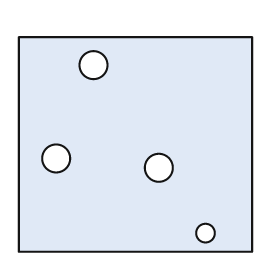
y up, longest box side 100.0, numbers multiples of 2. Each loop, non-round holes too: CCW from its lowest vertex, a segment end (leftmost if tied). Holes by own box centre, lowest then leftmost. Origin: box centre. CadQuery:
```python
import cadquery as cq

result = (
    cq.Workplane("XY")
    .moveTo(-50.0, -46.0)
    .lineTo(50.0, -46.0)
    .lineTo(50.0, 46.0)
    .lineTo(-50.0, 46.0)
    .close()
    .moveTo(30.0, -38.0)
    .circle(4.0)
    .moveTo(10.0, -10.0)
    .circle(6.0)
    .moveTo(-34.0, -6.0)
    .circle(6.0)
    .moveTo(-18.0, 34.0)
    .circle(6.0)
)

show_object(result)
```